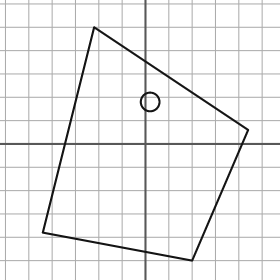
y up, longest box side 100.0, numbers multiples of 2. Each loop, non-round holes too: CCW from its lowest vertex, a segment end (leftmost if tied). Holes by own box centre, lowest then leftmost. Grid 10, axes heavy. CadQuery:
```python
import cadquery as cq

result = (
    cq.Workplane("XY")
    .moveTo(20.0, -50.0)
    .lineTo(44.0, 6.0)
    .lineTo(-22.0, 50.0)
    .lineTo(-44.0, -38.0)
    .close()
    .moveTo(2.0, 18.0)
    .circle(4.0)
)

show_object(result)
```